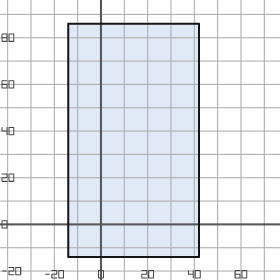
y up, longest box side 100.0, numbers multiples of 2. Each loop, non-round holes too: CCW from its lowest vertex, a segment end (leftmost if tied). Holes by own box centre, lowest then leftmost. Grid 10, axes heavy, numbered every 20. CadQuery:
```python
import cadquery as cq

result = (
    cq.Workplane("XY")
    .moveTo(-14.0, -14.0)
    .lineTo(42.0, -14.0)
    .lineTo(42.0, 86.0)
    .lineTo(-14.0, 86.0)
    .close()
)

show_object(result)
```